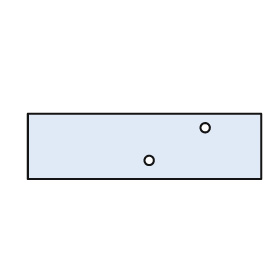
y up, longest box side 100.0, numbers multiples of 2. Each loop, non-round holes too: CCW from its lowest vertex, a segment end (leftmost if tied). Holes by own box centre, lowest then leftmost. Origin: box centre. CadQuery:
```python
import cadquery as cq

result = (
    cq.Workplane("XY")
    .moveTo(-50.0, -14.0)
    .lineTo(50.0, -14.0)
    .lineTo(50.0, 14.0)
    .lineTo(-50.0, 14.0)
    .close()
    .moveTo(2.0, -6.0)
    .circle(2.0)
    .moveTo(26.0, 8.0)
    .circle(2.0)
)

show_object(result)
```